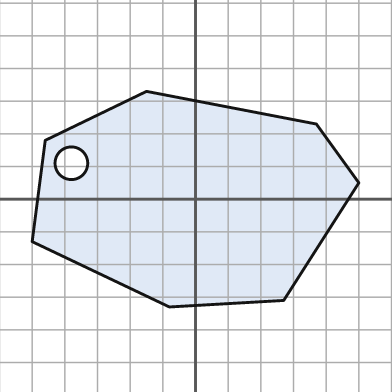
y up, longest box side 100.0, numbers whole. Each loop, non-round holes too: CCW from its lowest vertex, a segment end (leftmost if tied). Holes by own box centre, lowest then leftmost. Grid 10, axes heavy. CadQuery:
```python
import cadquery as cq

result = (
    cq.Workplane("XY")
    .moveTo(-8.0, -33.0)
    .lineTo(27.0, -31.0)
    .lineTo(50.0, 5.0)
    .lineTo(37.0, 23.0)
    .lineTo(-15.0, 33.0)
    .lineTo(-46.0, 18.0)
    .lineTo(-50.0, -13.0)
    .close()
    .moveTo(-38.0, 11.0)
    .circle(5.0)
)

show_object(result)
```